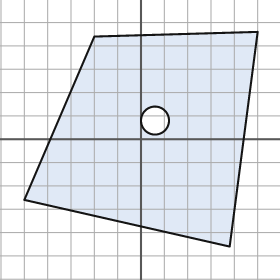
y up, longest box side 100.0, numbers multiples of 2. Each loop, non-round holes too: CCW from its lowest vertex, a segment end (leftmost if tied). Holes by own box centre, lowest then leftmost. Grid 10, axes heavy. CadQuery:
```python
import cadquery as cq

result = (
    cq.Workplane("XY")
    .moveTo(38.0, -46.0)
    .lineTo(50.0, 46.0)
    .lineTo(-20.0, 44.0)
    .lineTo(-50.0, -26.0)
    .close()
    .moveTo(6.0, 8.0)
    .circle(6.0)
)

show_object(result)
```